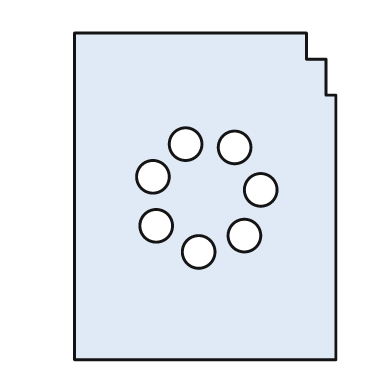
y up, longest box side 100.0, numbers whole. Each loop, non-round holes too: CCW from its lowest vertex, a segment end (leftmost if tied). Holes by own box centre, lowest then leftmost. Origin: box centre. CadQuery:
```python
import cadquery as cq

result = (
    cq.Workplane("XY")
    .moveTo(-40.0, -50.0)
    .lineTo(40.0, -50.0)
    .lineTo(40.0, 31.0)
    .lineTo(37.0, 31.0)
    .lineTo(37.0, 42.0)
    .lineTo(31.0, 42.0)
    .lineTo(31.0, 50.0)
    .lineTo(-40.0, 50.0)
    .close()
    .moveTo(-2.0, -17.0)
    .circle(5.0)
    .moveTo(12.0, -12.0)
    .circle(5.0)
    .moveTo(-15.0, -9.0)
    .circle(5.0)
    .moveTo(17.0, 2.0)
    .circle(5.0)
    .moveTo(-16.0, 6.0)
    .circle(5.0)
    .moveTo(9.0, 15.0)
    .circle(5.0)
    .moveTo(-6.0, 16.0)
    .circle(5.0)
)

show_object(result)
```